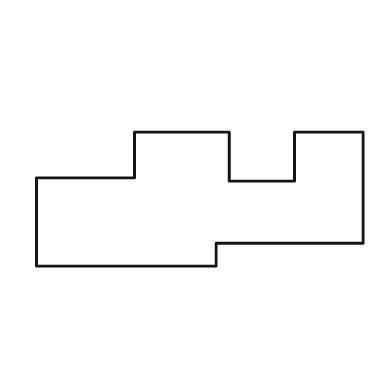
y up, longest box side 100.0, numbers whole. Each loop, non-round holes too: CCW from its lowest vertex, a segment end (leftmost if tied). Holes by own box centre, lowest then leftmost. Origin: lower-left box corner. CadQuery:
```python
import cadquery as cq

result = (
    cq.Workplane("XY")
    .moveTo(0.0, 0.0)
    .lineTo(55.0, 0.0)
    .lineTo(55.0, 7.0)
    .lineTo(100.0, 7.0)
    .lineTo(100.0, 41.0)
    .lineTo(79.0, 41.0)
    .lineTo(79.0, 26.0)
    .lineTo(59.0, 26.0)
    .lineTo(59.0, 41.0)
    .lineTo(30.0, 41.0)
    .lineTo(30.0, 27.0)
    .lineTo(0.0, 27.0)
    .close()
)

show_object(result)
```